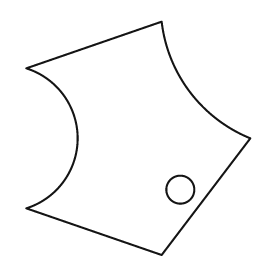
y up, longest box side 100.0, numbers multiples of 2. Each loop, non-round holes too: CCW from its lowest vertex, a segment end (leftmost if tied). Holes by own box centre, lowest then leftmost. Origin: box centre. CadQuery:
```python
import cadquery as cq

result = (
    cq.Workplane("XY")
    .moveTo(10.0, -50.0)
    .lineTo(48.0, 0.0)
    .threePointArc((22.0, 20.0), (10.0, 50.0))
    .lineTo(-48.0, 30.0)
    .threePointArc((-26.0, 0.0), (-48.0, -30.0))
    .close()
    .moveTo(18.0, -22.0)
    .circle(6.0)
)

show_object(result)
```